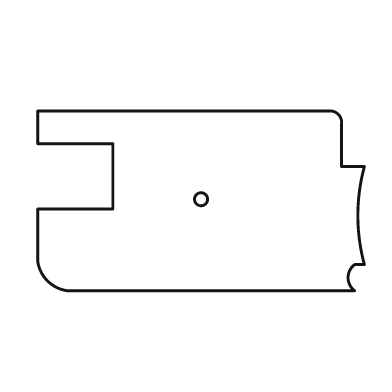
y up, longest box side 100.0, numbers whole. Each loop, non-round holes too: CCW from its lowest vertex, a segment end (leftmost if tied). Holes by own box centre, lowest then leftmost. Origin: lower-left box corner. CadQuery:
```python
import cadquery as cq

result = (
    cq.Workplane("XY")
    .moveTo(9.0, 0.0)
    .lineTo(97.0, 0.0)
    .threePointArc((95.0, 4.0), (97.0, 8.0))
    .lineTo(100.0, 8.0)
    .threePointArc((98.0, 23.0), (100.0, 38.0))
    .lineTo(93.0, 38.0)
    .lineTo(93.0, 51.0)
    .threePointArc((92.0, 54.0), (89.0, 55.0))
    .lineTo(0.0, 55.0)
    .lineTo(0.0, 45.0)
    .lineTo(23.0, 45.0)
    .lineTo(23.0, 25.0)
    .lineTo(0.0, 25.0)
    .lineTo(0.0, 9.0)
    .threePointArc((3.0, 3.0), (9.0, 0.0))
    .close()
    .moveTo(50.0, 28.0)
    .circle(2.0)
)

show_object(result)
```